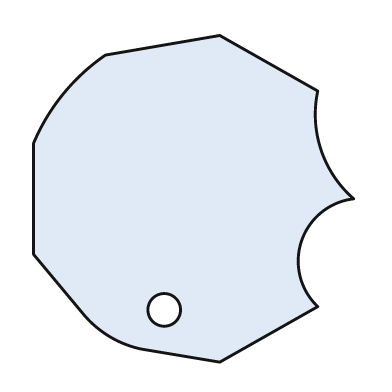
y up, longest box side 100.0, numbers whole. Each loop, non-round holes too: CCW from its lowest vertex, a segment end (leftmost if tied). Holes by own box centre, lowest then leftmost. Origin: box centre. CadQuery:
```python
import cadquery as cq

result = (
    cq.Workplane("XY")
    .moveTo(8.0, -50.0)
    .lineTo(38.0, -33.0)
    .threePointArc((33.0, -13.0), (49.0, 0.0))
    .threePointArc((39.0, 15.0), (38.0, 33.0))
    .lineTo(8.0, 50.0)
    .lineTo(-27.0, 44.0)
    .threePointArc((-40.0, 32.0), (-49.0, 17.0))
    .lineTo(-49.0, -17.0)
    .lineTo(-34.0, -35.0)
    .threePointArc((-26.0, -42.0), (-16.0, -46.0))
    .close()
    .moveTo(-9.0, -34.0)
    .circle(5.0)
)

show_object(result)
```